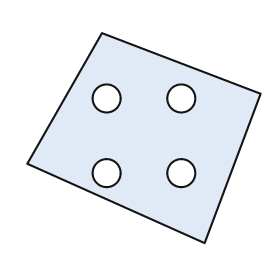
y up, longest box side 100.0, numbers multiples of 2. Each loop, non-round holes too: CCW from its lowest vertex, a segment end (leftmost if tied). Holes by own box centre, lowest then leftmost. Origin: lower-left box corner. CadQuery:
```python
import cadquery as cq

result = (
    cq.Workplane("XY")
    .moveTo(76.0, 0.0)
    .lineTo(100.0, 64.0)
    .lineTo(32.0, 90.0)
    .lineTo(0.0, 34.0)
    .close()
    .moveTo(34.0, 30.0)
    .circle(6.0)
    .moveTo(66.0, 30.0)
    .circle(6.0)
    .moveTo(34.0, 62.0)
    .circle(6.0)
    .moveTo(66.0, 62.0)
    .circle(6.0)
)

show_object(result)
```